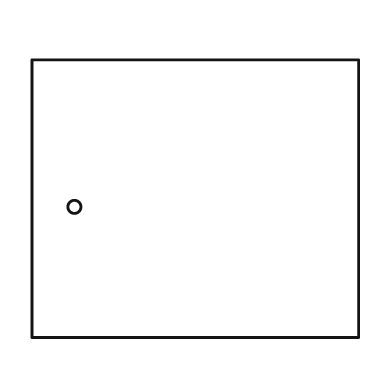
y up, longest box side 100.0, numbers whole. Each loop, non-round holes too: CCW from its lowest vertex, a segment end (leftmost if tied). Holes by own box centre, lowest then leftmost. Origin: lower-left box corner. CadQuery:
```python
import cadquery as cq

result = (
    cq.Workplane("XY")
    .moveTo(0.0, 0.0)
    .lineTo(100.0, 0.0)
    .lineTo(100.0, 85.0)
    .lineTo(0.0, 85.0)
    .close()
    .moveTo(13.0, 40.0)
    .circle(2.0)
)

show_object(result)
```